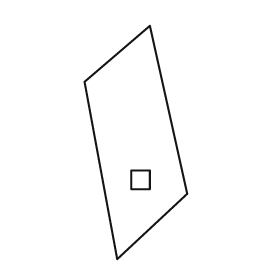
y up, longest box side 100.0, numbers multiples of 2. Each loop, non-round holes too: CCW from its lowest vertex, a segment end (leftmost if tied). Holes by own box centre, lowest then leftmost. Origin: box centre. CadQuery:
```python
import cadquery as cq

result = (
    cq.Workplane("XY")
    .moveTo(-8.0, -50.0)
    .lineTo(22.0, -22.0)
    .lineTo(6.0, 50.0)
    .lineTo(-22.0, 26.0)
    .close()
    .moveTo(-2.0, -20.0)
    .lineTo(6.0, -20.0)
    .lineTo(6.0, -12.0)
    .lineTo(-2.0, -12.0)
    .close()
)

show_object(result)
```